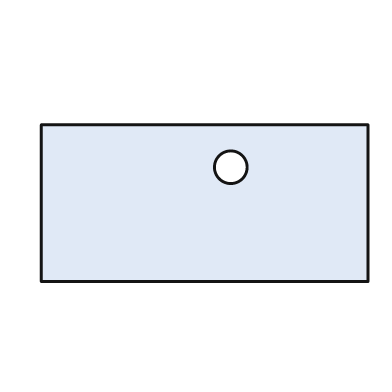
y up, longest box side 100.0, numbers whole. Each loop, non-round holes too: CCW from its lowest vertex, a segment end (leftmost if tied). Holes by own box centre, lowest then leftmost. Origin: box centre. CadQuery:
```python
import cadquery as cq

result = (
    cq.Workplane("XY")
    .moveTo(-50.0, -24.0)
    .lineTo(50.0, -24.0)
    .lineTo(50.0, 24.0)
    .lineTo(-50.0, 24.0)
    .close()
    .moveTo(8.0, 11.0)
    .circle(5.0)
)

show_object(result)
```